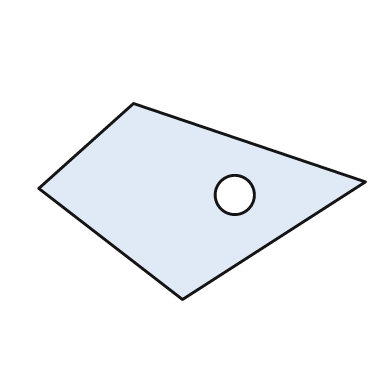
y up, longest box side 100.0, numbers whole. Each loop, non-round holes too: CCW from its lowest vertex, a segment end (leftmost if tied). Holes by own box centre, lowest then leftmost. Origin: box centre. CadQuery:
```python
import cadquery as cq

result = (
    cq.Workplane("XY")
    .moveTo(-6.0, -30.0)
    .lineTo(50.0, 6.0)
    .lineTo(-21.0, 30.0)
    .lineTo(-50.0, 4.0)
    .close()
    .moveTo(10.0, 2.0)
    .circle(6.0)
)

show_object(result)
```